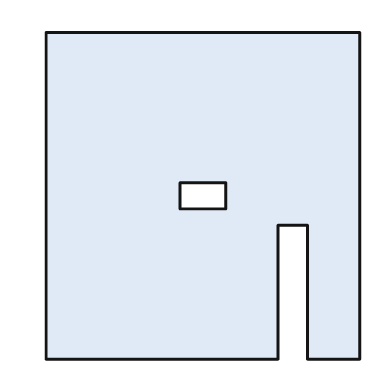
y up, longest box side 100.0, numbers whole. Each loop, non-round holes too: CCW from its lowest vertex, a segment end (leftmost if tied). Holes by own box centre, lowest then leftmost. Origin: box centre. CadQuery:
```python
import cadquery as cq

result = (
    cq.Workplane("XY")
    .moveTo(-48.0, -50.0)
    .lineTo(23.0, -50.0)
    .lineTo(23.0, -9.0)
    .lineTo(32.0, -9.0)
    .lineTo(32.0, -50.0)
    .lineTo(48.0, -50.0)
    .lineTo(48.0, 50.0)
    .lineTo(-48.0, 50.0)
    .close()
    .moveTo(-7.0, -4.0)
    .lineTo(7.0, -4.0)
    .lineTo(7.0, 4.0)
    .lineTo(-7.0, 4.0)
    .close()
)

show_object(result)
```